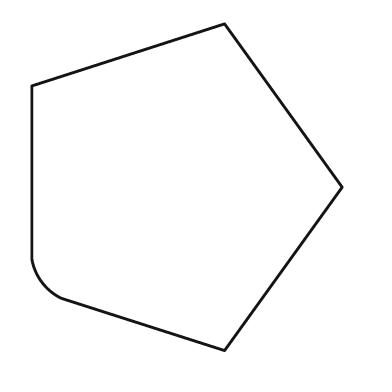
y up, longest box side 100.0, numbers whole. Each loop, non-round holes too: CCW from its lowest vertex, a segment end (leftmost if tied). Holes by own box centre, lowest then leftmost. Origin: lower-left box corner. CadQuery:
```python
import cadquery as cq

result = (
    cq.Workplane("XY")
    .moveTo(59.0, 0.0)
    .lineTo(95.0, 50.0)
    .lineTo(59.0, 100.0)
    .lineTo(0.0, 81.0)
    .lineTo(0.0, 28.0)
    .threePointArc((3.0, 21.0), (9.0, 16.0))
    .close()
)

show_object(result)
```